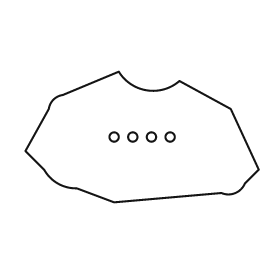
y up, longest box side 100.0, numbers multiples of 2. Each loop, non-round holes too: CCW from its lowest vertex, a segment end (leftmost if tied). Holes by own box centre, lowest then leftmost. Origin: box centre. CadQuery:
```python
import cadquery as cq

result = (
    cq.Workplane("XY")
    .moveTo(-12.0, -28.0)
    .lineTo(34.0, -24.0)
    .threePointArc((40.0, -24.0), (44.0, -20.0))
    .lineTo(50.0, -14.0)
    .lineTo(38.0, 12.0)
    .lineTo(16.0, 24.0)
    .threePointArc((2.0, 20.0), (-10.0, 28.0))
    .lineTo(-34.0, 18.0)
    .threePointArc((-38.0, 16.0), (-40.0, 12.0))
    .lineTo(-50.0, -6.0)
    .lineTo(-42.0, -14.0)
    .threePointArc((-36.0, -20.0), (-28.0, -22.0))
    .close()
    .moveTo(-12.0, 0.0)
    .circle(2.0)
    .moveTo(-4.0, 0.0)
    .circle(2.0)
    .moveTo(4.0, 0.0)
    .circle(2.0)
    .moveTo(12.0, 0.0)
    .circle(2.0)
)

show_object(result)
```